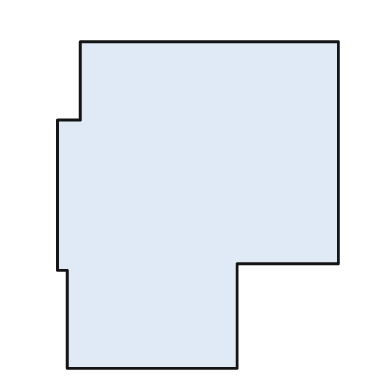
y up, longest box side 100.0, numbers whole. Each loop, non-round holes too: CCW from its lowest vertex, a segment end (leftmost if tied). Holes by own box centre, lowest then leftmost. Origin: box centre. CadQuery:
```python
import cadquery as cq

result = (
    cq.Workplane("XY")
    .moveTo(-40.0, -50.0)
    .lineTo(12.0, -50.0)
    .lineTo(12.0, -18.0)
    .lineTo(43.0, -18.0)
    .lineTo(43.0, 50.0)
    .lineTo(-36.0, 50.0)
    .lineTo(-36.0, 26.0)
    .lineTo(-43.0, 26.0)
    .lineTo(-43.0, -20.0)
    .lineTo(-40.0, -20.0)
    .close()
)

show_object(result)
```